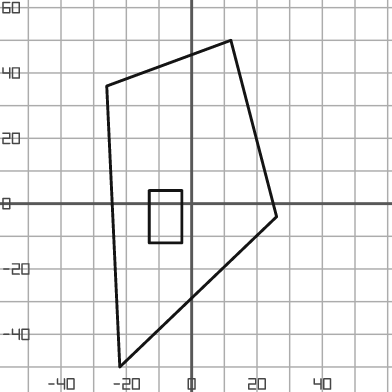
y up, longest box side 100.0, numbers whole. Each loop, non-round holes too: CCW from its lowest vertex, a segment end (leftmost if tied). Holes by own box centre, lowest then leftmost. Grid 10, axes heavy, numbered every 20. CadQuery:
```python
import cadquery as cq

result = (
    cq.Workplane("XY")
    .moveTo(-22.0, -50.0)
    .lineTo(26.0, -4.0)
    .lineTo(12.0, 50.0)
    .lineTo(-26.0, 36.0)
    .close()
    .moveTo(-13.0, -12.0)
    .lineTo(-3.0, -12.0)
    .lineTo(-3.0, 4.0)
    .lineTo(-13.0, 4.0)
    .close()
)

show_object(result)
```